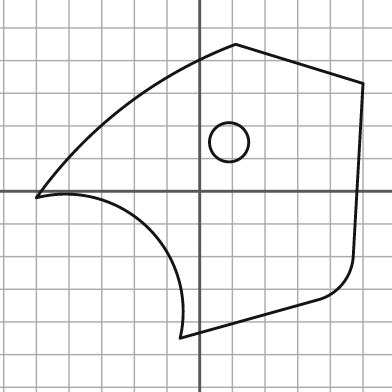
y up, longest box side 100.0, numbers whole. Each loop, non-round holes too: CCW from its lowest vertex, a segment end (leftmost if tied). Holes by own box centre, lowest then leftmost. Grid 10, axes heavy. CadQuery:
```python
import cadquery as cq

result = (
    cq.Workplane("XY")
    .moveTo(-6.0, -45.0)
    .lineTo(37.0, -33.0)
    .threePointArc((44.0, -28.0), (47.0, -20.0))
    .lineTo(50.0, 33.0)
    .lineTo(11.0, 45.0)
    .threePointArc((-23.0, 26.0), (-50.0, -2.0))
    .threePointArc((-16.0, -11.0), (-6.0, -45.0))
    .close()
    .moveTo(9.0, 15.0)
    .circle(6.0)
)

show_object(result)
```